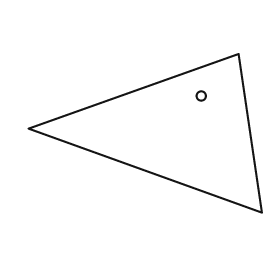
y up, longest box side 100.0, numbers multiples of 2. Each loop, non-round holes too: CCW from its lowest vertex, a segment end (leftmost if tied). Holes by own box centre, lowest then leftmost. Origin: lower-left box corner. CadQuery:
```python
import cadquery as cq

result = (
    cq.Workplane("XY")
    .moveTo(100.0, 0.0)
    .lineTo(90.0, 68.0)
    .lineTo(0.0, 36.0)
    .close()
    .moveTo(74.0, 50.0)
    .circle(2.0)
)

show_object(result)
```